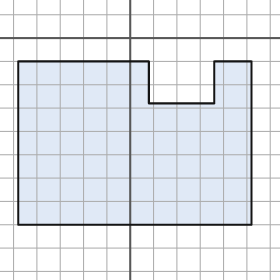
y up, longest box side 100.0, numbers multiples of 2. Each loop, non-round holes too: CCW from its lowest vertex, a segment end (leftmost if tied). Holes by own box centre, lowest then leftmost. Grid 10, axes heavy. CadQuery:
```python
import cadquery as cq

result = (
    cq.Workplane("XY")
    .moveTo(-48.0, -80.0)
    .lineTo(52.0, -80.0)
    .lineTo(52.0, -10.0)
    .lineTo(36.0, -10.0)
    .lineTo(36.0, -28.0)
    .lineTo(8.0, -28.0)
    .lineTo(8.0, -10.0)
    .lineTo(-48.0, -10.0)
    .close()
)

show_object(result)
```